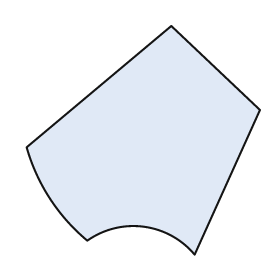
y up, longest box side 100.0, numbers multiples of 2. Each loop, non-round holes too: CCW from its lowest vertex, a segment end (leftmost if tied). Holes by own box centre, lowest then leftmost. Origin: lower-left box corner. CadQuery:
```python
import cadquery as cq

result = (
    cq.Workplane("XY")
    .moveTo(72.0, 0.0)
    .lineTo(100.0, 62.0)
    .lineTo(62.0, 98.0)
    .lineTo(0.0, 46.0)
    .threePointArc((10.0, 24.0), (26.0, 6.0))
    .threePointArc((50.0, 12.0), (72.0, 0.0))
    .close()
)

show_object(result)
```